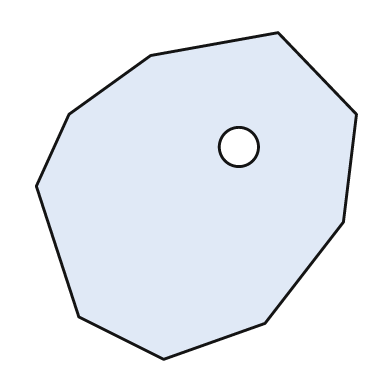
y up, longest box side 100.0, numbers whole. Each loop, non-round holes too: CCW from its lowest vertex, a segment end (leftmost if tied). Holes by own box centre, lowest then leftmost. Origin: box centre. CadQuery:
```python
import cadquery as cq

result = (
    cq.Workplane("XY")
    .moveTo(-10.0, -50.0)
    .lineTo(21.0, -39.0)
    .lineTo(45.0, -8.0)
    .lineTo(49.0, 25.0)
    .lineTo(25.0, 50.0)
    .lineTo(-14.0, 43.0)
    .lineTo(-39.0, 25.0)
    .lineTo(-49.0, 3.0)
    .lineTo(-36.0, -37.0)
    .close()
    .moveTo(13.0, 15.0)
    .circle(6.0)
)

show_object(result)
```